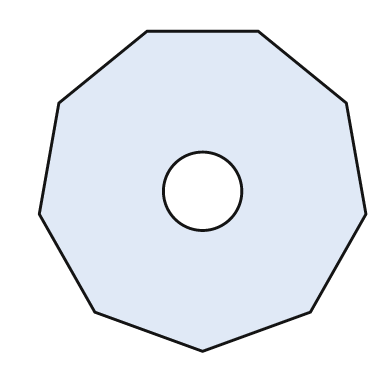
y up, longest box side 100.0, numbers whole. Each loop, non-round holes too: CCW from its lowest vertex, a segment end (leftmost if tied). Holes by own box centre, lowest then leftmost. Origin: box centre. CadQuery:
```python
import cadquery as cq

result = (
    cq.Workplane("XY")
    .moveTo(0.0, -49.0)
    .lineTo(33.0, -37.0)
    .lineTo(50.0, -7.0)
    .lineTo(44.0, 27.0)
    .lineTo(17.0, 49.0)
    .lineTo(-17.0, 49.0)
    .lineTo(-44.0, 27.0)
    .lineTo(-50.0, -7.0)
    .lineTo(-33.0, -37.0)
    .close()
    .moveTo(0.0, 0.0)
    .circle(12.0)
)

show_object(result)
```